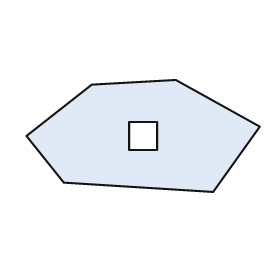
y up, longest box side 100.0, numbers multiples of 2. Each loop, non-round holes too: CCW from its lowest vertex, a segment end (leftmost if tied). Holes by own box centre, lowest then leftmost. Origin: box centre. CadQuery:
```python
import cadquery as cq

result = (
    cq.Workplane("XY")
    .moveTo(30.0, -24.0)
    .lineTo(50.0, 4.0)
    .lineTo(14.0, 24.0)
    .lineTo(-22.0, 22.0)
    .lineTo(-50.0, 0.0)
    .lineTo(-34.0, -20.0)
    .close()
    .moveTo(-6.0, -6.0)
    .lineTo(6.0, -6.0)
    .lineTo(6.0, 6.0)
    .lineTo(-6.0, 6.0)
    .close()
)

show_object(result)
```